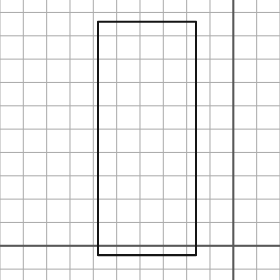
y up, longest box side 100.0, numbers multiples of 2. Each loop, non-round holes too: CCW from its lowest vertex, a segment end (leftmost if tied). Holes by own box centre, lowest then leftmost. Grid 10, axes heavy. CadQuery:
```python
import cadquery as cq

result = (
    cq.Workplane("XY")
    .moveTo(-58.0, -4.0)
    .lineTo(-16.0, -4.0)
    .lineTo(-16.0, 96.0)
    .lineTo(-58.0, 96.0)
    .close()
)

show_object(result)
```